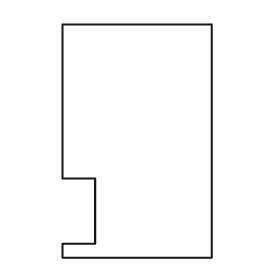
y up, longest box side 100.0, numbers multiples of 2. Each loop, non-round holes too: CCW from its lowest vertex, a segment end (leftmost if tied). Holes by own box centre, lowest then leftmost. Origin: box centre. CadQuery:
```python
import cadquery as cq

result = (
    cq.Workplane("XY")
    .moveTo(-32.0, -50.0)
    .lineTo(32.0, -50.0)
    .lineTo(32.0, 50.0)
    .lineTo(-32.0, 50.0)
    .lineTo(-32.0, -16.0)
    .lineTo(-18.0, -16.0)
    .lineTo(-18.0, -44.0)
    .lineTo(-32.0, -44.0)
    .close()
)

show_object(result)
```